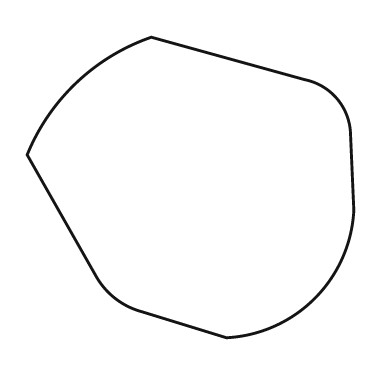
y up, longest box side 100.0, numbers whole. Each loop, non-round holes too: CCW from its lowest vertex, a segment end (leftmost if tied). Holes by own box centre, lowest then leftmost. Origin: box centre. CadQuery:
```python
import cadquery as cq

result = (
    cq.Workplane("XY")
    .moveTo(11.0, -46.0)
    .threePointArc((38.0, -34.0), (50.0, -7.0))
    .lineTo(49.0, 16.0)
    .threePointArc((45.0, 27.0), (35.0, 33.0))
    .lineTo(-12.0, 46.0)
    .threePointArc((-35.0, 32.0), (-50.0, 10.0))
    .lineTo(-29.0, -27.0)
    .threePointArc((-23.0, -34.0), (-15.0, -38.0))
    .close()
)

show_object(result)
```